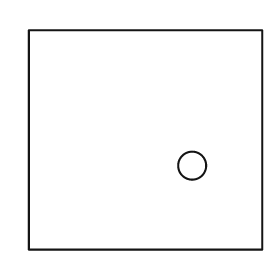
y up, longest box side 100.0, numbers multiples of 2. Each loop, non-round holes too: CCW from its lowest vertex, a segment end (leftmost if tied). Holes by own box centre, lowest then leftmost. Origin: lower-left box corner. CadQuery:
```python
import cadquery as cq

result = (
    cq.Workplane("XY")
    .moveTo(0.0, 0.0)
    .lineTo(100.0, 0.0)
    .lineTo(100.0, 94.0)
    .lineTo(0.0, 94.0)
    .close()
    .moveTo(70.0, 36.0)
    .circle(6.0)
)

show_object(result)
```